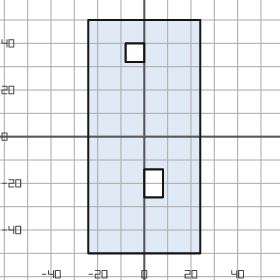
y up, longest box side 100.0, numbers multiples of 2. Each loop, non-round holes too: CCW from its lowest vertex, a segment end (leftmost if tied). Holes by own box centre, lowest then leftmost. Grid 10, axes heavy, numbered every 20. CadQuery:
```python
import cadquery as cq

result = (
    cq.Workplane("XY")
    .moveTo(-24.0, -50.0)
    .lineTo(24.0, -50.0)
    .lineTo(24.0, 50.0)
    .lineTo(-24.0, 50.0)
    .close()
    .moveTo(0.0, -26.0)
    .lineTo(8.0, -26.0)
    .lineTo(8.0, -14.0)
    .lineTo(0.0, -14.0)
    .close()
    .moveTo(-8.0, 32.0)
    .lineTo(0.0, 32.0)
    .lineTo(0.0, 40.0)
    .lineTo(-8.0, 40.0)
    .close()
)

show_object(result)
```